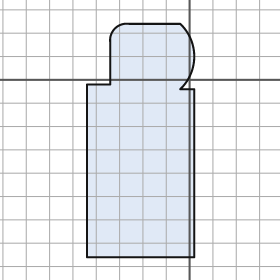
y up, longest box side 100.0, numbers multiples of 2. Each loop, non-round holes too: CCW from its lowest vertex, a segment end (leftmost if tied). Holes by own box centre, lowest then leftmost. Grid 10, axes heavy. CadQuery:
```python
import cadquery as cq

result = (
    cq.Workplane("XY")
    .moveTo(-44.0, -76.0)
    .lineTo(2.0, -76.0)
    .lineTo(2.0, -4.0)
    .lineTo(-4.0, -4.0)
    .threePointArc((2.0, 10.0), (-4.0, 24.0))
    .lineTo(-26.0, 24.0)
    .threePointArc((-32.0, 22.0), (-34.0, 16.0))
    .lineTo(-34.0, -2.0)
    .lineTo(-44.0, -2.0)
    .close()
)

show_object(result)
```